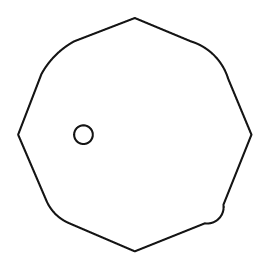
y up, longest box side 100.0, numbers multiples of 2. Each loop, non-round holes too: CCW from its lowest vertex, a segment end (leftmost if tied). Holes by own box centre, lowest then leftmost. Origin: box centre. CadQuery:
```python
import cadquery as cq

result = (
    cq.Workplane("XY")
    .moveTo(0.0, -50.0)
    .lineTo(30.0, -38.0)
    .threePointArc((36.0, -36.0), (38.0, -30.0))
    .lineTo(50.0, 0.0)
    .lineTo(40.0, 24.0)
    .threePointArc((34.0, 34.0), (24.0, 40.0))
    .lineTo(0.0, 50.0)
    .lineTo(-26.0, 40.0)
    .threePointArc((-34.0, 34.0), (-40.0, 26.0))
    .lineTo(-50.0, 0.0)
    .lineTo(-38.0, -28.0)
    .threePointArc((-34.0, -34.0), (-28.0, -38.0))
    .close()
    .moveTo(-22.0, 0.0)
    .circle(4.0)
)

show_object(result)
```